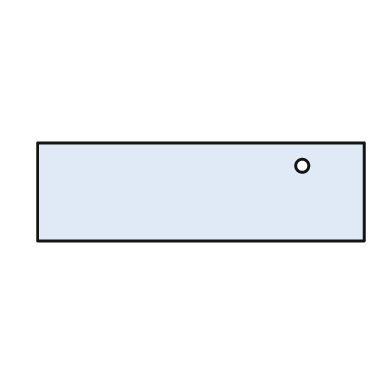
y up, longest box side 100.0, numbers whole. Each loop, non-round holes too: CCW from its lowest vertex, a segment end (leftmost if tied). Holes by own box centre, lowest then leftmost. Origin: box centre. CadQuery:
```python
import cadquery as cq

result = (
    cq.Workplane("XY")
    .moveTo(-50.0, -15.0)
    .lineTo(50.0, -15.0)
    .lineTo(50.0, 15.0)
    .lineTo(-50.0, 15.0)
    .close()
    .moveTo(31.0, 8.0)
    .circle(2.0)
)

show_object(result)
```